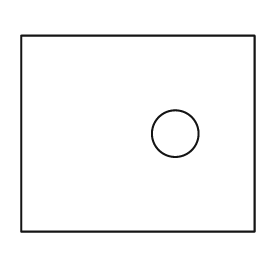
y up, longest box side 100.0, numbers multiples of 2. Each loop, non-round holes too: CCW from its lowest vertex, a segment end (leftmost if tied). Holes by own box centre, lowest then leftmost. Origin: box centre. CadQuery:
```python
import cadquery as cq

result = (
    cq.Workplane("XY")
    .moveTo(-50.0, -42.0)
    .lineTo(50.0, -42.0)
    .lineTo(50.0, 42.0)
    .lineTo(-50.0, 42.0)
    .close()
    .moveTo(16.0, 0.0)
    .circle(10.0)
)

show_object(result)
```